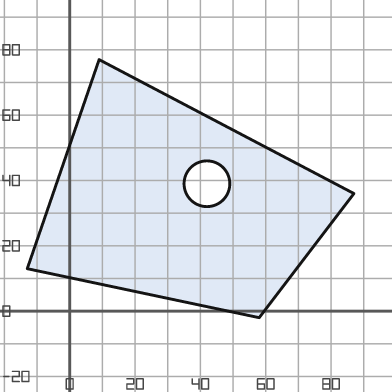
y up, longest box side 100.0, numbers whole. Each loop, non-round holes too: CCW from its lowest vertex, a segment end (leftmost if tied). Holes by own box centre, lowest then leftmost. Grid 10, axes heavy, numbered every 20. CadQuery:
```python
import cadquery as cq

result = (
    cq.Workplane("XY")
    .moveTo(58.0, -2.0)
    .lineTo(87.0, 36.0)
    .lineTo(9.0, 77.0)
    .lineTo(-13.0, 13.0)
    .close()
    .moveTo(42.0, 39.0)
    .circle(7.0)
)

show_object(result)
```